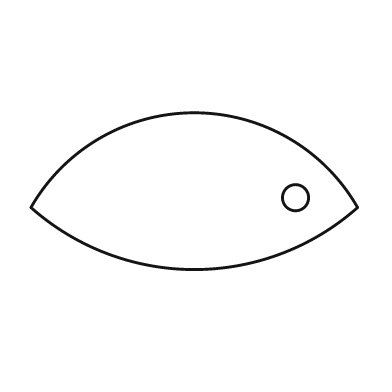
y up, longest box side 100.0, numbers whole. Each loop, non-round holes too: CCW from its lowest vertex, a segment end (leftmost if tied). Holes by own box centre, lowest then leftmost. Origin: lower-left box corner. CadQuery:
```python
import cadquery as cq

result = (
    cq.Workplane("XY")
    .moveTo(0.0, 19.0)
    .threePointArc((50.0, 0.0), (100.0, 19.0))
    .threePointArc((50.0, 48.0), (0.0, 19.0))
    .close()
    .moveTo(81.0, 22.0)
    .circle(4.0)
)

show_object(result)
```